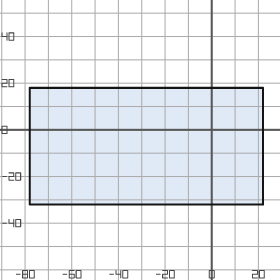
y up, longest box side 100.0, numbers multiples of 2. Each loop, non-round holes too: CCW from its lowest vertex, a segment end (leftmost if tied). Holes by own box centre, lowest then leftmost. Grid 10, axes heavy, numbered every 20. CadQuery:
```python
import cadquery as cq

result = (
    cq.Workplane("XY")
    .moveTo(-78.0, -32.0)
    .lineTo(22.0, -32.0)
    .lineTo(22.0, 18.0)
    .lineTo(-78.0, 18.0)
    .close()
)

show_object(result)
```